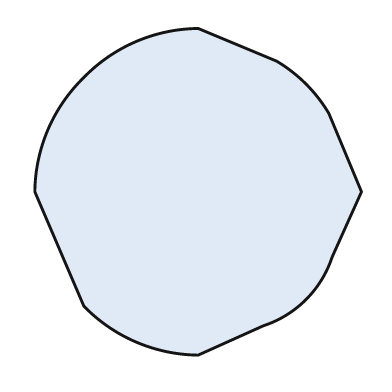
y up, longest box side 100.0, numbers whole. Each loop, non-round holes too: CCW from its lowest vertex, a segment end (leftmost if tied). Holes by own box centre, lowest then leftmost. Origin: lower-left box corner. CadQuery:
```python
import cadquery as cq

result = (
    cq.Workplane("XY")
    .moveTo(50.0, 0.0)
    .lineTo(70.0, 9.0)
    .threePointArc((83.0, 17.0), (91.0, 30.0))
    .lineTo(100.0, 50.0)
    .lineTo(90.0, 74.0)
    .threePointArc((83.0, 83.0), (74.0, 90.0))
    .lineTo(50.0, 100.0)
    .threePointArc((31.0, 96.0), (15.0, 85.0))
    .threePointArc((4.0, 69.0), (0.0, 50.0))
    .lineTo(15.0, 15.0)
    .threePointArc((31.0, 4.0), (50.0, 0.0))
    .close()
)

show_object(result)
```